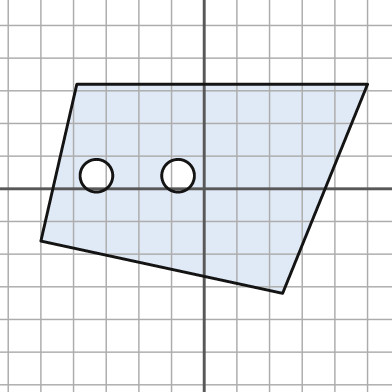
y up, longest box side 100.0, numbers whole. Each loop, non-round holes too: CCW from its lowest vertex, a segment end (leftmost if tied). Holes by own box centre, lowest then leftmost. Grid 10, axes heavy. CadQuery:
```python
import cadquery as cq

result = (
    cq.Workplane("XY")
    .moveTo(24.0, -32.0)
    .lineTo(50.0, 32.0)
    .lineTo(-39.0, 32.0)
    .lineTo(-50.0, -16.0)
    .close()
    .moveTo(-33.0, 4.0)
    .circle(5.0)
    .moveTo(-8.0, 4.0)
    .circle(5.0)
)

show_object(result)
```